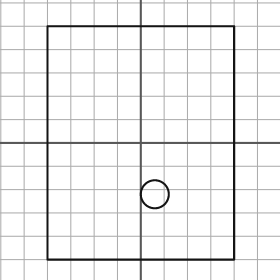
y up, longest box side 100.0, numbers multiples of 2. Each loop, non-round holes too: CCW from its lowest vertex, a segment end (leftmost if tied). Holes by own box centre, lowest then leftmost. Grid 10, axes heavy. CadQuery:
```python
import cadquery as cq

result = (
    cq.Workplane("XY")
    .moveTo(-40.0, -50.0)
    .lineTo(40.0, -50.0)
    .lineTo(40.0, 50.0)
    .lineTo(-40.0, 50.0)
    .close()
    .moveTo(6.0, -22.0)
    .circle(6.0)
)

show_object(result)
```